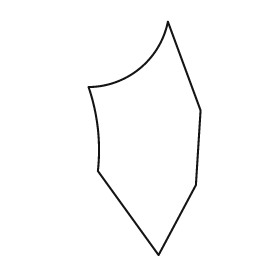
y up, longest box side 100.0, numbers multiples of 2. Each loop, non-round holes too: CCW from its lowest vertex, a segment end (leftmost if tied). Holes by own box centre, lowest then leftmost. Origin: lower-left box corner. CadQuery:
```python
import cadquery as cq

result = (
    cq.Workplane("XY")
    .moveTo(30.0, 0.0)
    .lineTo(46.0, 30.0)
    .lineTo(48.0, 62.0)
    .lineTo(34.0, 100.0)
    .threePointArc((22.0, 80.0), (0.0, 72.0))
    .threePointArc((4.0, 54.0), (4.0, 36.0))
    .close()
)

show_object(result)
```